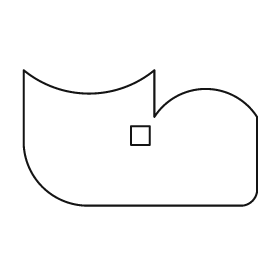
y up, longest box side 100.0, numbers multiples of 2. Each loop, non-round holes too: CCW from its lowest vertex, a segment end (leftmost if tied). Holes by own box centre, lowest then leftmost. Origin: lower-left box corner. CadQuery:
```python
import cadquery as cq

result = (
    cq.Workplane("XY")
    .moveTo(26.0, 0.0)
    .lineTo(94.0, 0.0)
    .threePointArc((98.0, 2.0), (100.0, 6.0))
    .lineTo(100.0, 38.0)
    .threePointArc((78.0, 50.0), (56.0, 38.0))
    .lineTo(56.0, 58.0)
    .threePointArc((28.0, 48.0), (0.0, 58.0))
    .lineTo(0.0, 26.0)
    .threePointArc((8.0, 8.0), (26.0, 0.0))
    .close()
    .moveTo(46.0, 26.0)
    .lineTo(54.0, 26.0)
    .lineTo(54.0, 34.0)
    .lineTo(46.0, 34.0)
    .close()
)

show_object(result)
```